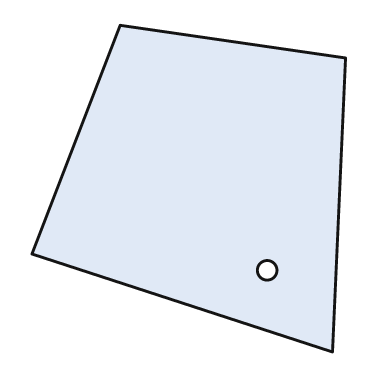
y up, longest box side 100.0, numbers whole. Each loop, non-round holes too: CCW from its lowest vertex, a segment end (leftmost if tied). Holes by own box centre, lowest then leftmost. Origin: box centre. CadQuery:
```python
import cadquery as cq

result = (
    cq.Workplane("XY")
    .moveTo(44.0, -50.0)
    .lineTo(48.0, 40.0)
    .lineTo(-21.0, 50.0)
    .lineTo(-48.0, -20.0)
    .close()
    .moveTo(24.0, -25.0)
    .circle(3.0)
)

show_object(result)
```